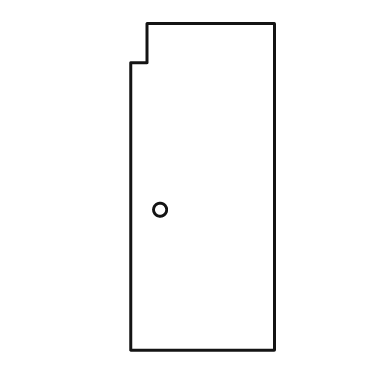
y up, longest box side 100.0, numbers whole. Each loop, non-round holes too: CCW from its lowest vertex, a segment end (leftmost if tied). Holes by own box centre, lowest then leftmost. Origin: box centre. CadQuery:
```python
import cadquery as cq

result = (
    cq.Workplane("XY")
    .moveTo(-22.0, -50.0)
    .lineTo(22.0, -50.0)
    .lineTo(22.0, 50.0)
    .lineTo(-17.0, 50.0)
    .lineTo(-17.0, 38.0)
    .lineTo(-22.0, 38.0)
    .close()
    .moveTo(-13.0, -7.0)
    .circle(2.0)
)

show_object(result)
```